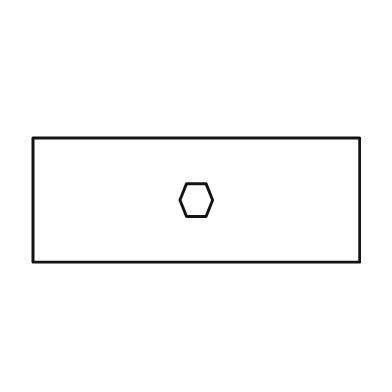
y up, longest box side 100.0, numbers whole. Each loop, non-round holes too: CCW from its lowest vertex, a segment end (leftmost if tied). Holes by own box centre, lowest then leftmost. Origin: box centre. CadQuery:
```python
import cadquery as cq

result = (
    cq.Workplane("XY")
    .moveTo(-50.0, -19.0)
    .lineTo(50.0, -19.0)
    .lineTo(50.0, 19.0)
    .lineTo(-50.0, 19.0)
    .close()
    .moveTo(-3.0, -5.0)
    .lineTo(3.0, -5.0)
    .lineTo(5.0, 0.0)
    .lineTo(3.0, 5.0)
    .lineTo(-3.0, 5.0)
    .lineTo(-5.0, 0.0)
    .close()
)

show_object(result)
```